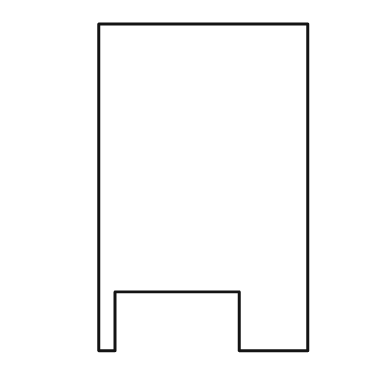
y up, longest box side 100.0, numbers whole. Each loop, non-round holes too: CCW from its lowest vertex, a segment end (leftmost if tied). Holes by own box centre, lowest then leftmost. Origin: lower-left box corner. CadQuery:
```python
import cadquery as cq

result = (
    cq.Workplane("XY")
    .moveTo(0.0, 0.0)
    .lineTo(5.0, 0.0)
    .lineTo(5.0, 18.0)
    .lineTo(43.0, 18.0)
    .lineTo(43.0, 0.0)
    .lineTo(64.0, 0.0)
    .lineTo(64.0, 100.0)
    .lineTo(0.0, 100.0)
    .close()
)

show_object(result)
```